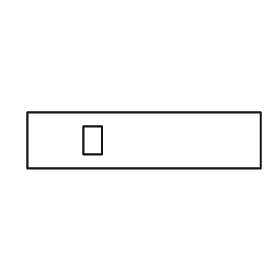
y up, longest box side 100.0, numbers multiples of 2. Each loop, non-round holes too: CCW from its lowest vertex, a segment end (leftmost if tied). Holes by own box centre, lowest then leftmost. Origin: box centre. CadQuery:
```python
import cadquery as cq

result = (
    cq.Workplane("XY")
    .moveTo(-50.0, -12.0)
    .lineTo(50.0, -12.0)
    .lineTo(50.0, 12.0)
    .lineTo(-50.0, 12.0)
    .close()
    .moveTo(-26.0, -6.0)
    .lineTo(-18.0, -6.0)
    .lineTo(-18.0, 6.0)
    .lineTo(-26.0, 6.0)
    .close()
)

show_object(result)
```